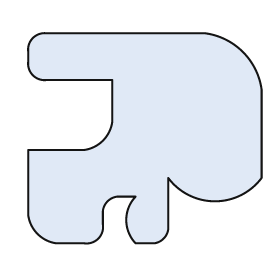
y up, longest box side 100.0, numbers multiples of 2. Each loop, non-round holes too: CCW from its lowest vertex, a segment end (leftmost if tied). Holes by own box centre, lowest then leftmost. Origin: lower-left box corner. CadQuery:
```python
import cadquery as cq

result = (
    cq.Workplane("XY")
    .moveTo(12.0, 0.0)
    .lineTo(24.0, 0.0)
    .threePointArc((30.0, 2.0), (32.0, 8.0))
    .lineTo(32.0, 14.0)
    .threePointArc((34.0, 18.0), (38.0, 20.0))
    .lineTo(46.0, 20.0)
    .threePointArc((42.0, 10.0), (46.0, 0.0))
    .lineTo(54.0, 0.0)
    .threePointArc((58.0, 2.0), (60.0, 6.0))
    .lineTo(60.0, 28.0)
    .threePointArc((80.0, 18.0), (100.0, 28.0))
    .lineTo(100.0, 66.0)
    .threePointArc((92.0, 82.0), (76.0, 90.0))
    .lineTo(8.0, 90.0)
    .threePointArc((2.0, 88.0), (0.0, 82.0))
    .lineTo(0.0, 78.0)
    .threePointArc((2.0, 72.0), (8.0, 70.0))
    .lineTo(36.0, 70.0)
    .lineTo(36.0, 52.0)
    .threePointArc((32.0, 44.0), (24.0, 40.0))
    .lineTo(0.0, 40.0)
    .lineTo(0.0, 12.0)
    .threePointArc((4.0, 4.0), (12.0, 0.0))
    .close()
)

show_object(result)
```